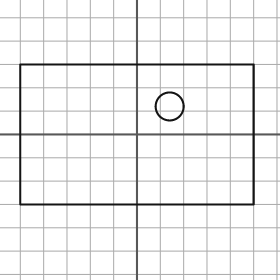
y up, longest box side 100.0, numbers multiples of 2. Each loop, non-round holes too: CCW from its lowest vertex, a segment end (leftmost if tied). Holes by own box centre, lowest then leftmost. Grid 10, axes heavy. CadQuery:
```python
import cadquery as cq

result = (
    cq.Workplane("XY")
    .moveTo(-50.0, -30.0)
    .lineTo(50.0, -30.0)
    .lineTo(50.0, 30.0)
    .lineTo(-50.0, 30.0)
    .close()
    .moveTo(14.0, 12.0)
    .circle(6.0)
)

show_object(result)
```